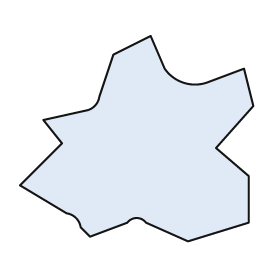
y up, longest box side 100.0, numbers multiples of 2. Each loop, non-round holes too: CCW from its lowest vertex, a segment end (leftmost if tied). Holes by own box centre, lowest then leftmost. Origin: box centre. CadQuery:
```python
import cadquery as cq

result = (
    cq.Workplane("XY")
    .moveTo(22.0, -44.0)
    .lineTo(48.0, -36.0)
    .lineTo(48.0, -16.0)
    .lineTo(34.0, -4.0)
    .lineTo(50.0, 14.0)
    .lineTo(46.0, 30.0)
    .lineTo(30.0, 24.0)
    .threePointArc((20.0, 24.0), (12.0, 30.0))
    .lineTo(6.0, 44.0)
    .lineTo(-10.0, 36.0)
    .lineTo(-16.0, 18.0)
    .threePointArc((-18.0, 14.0), (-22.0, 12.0))
    .lineTo(-40.0, 8.0)
    .lineTo(-32.0, -2.0)
    .lineTo(-50.0, -20.0)
    .lineTo(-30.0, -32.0)
    .threePointArc((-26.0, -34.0), (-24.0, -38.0))
    .lineTo(-20.0, -42.0)
    .lineTo(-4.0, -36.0)
    .threePointArc((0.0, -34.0), (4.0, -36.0))
    .close()
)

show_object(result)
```